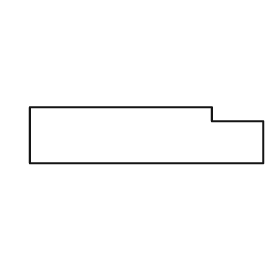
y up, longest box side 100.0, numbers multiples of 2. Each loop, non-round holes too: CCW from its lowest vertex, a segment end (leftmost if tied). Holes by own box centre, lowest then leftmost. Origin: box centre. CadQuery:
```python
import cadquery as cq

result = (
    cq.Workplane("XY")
    .moveTo(-50.0, -12.0)
    .lineTo(50.0, -12.0)
    .lineTo(50.0, 6.0)
    .lineTo(28.0, 6.0)
    .lineTo(28.0, 12.0)
    .lineTo(-50.0, 12.0)
    .close()
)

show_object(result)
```